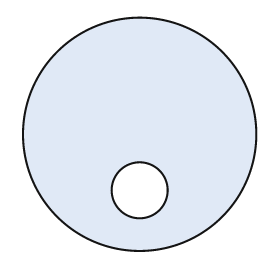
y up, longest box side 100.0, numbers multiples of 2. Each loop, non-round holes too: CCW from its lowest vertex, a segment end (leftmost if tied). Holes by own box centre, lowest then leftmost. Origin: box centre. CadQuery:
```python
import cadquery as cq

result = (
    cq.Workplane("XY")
    .moveTo(0.0, 0.0)
    .circle(50.0)
    .moveTo(0.0, -24.0)
    .circle(12.0)
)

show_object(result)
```